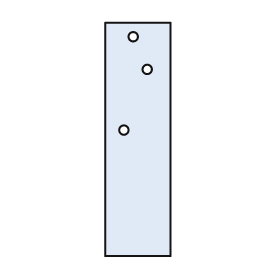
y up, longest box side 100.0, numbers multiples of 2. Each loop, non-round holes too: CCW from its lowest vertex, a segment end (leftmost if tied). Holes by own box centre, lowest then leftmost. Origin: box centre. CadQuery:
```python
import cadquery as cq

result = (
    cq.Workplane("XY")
    .moveTo(-14.0, -50.0)
    .lineTo(14.0, -50.0)
    .lineTo(14.0, 50.0)
    .lineTo(-14.0, 50.0)
    .close()
    .moveTo(-6.0, 4.0)
    .circle(2.0)
    .moveTo(4.0, 30.0)
    .circle(2.0)
    .moveTo(-2.0, 44.0)
    .circle(2.0)
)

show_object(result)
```